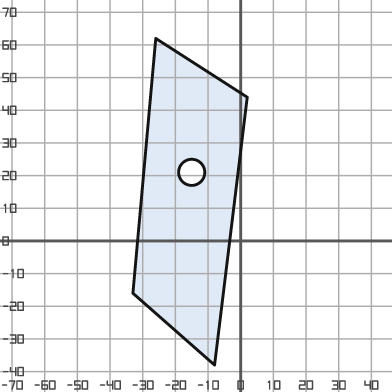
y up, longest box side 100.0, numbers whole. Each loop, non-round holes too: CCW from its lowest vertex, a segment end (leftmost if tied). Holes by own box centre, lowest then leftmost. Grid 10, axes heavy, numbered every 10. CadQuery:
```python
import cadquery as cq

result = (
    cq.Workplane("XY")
    .moveTo(-8.0, -38.0)
    .lineTo(2.0, 44.0)
    .lineTo(-26.0, 62.0)
    .lineTo(-33.0, -16.0)
    .close()
    .moveTo(-15.0, 21.0)
    .circle(4.0)
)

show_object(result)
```